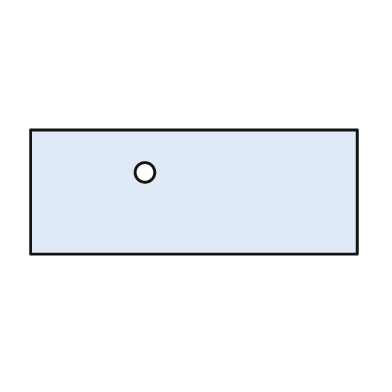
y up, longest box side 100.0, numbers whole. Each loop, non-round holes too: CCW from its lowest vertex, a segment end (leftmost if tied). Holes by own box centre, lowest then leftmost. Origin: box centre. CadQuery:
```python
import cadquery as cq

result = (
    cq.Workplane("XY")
    .moveTo(-50.0, -19.0)
    .lineTo(50.0, -19.0)
    .lineTo(50.0, 19.0)
    .lineTo(-50.0, 19.0)
    .close()
    .moveTo(-15.0, 6.0)
    .circle(3.0)
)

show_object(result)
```